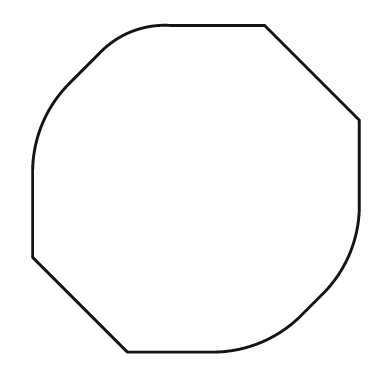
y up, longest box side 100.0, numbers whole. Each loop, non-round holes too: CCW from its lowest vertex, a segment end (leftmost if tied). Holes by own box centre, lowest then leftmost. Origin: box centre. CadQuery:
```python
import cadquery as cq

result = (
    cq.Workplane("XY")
    .moveTo(-21.0, -50.0)
    .lineTo(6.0, -50.0)
    .threePointArc((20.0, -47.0), (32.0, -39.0))
    .lineTo(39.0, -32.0)
    .threePointArc((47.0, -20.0), (50.0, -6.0))
    .lineTo(50.0, 21.0)
    .lineTo(21.0, 50.0)
    .lineTo(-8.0, 50.0)
    .threePointArc((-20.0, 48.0), (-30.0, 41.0))
    .lineTo(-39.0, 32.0)
    .threePointArc((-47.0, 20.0), (-50.0, 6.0))
    .lineTo(-50.0, -21.0)
    .close()
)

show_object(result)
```